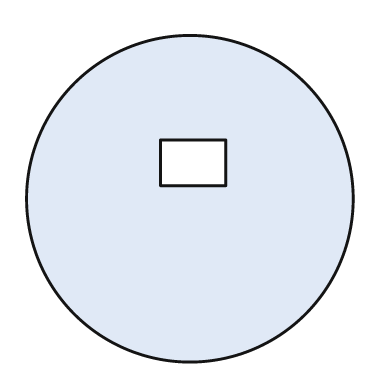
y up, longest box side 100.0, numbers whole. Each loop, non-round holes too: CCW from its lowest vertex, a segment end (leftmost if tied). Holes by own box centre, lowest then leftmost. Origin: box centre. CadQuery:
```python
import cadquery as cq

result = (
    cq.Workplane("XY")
    .moveTo(0.0, 0.0)
    .circle(50.0)
    .moveTo(-9.0, 4.0)
    .lineTo(11.0, 4.0)
    .lineTo(11.0, 18.0)
    .lineTo(-9.0, 18.0)
    .close()
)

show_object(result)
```